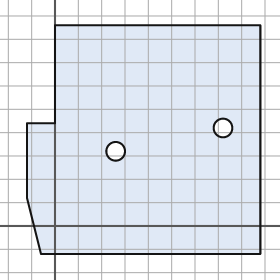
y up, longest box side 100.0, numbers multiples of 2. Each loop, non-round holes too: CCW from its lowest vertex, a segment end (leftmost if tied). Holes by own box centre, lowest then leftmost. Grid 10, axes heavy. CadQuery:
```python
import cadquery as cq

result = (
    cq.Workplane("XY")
    .moveTo(-6.0, -12.0)
    .lineTo(88.0, -12.0)
    .lineTo(88.0, 86.0)
    .lineTo(0.0, 86.0)
    .lineTo(0.0, 44.0)
    .lineTo(-12.0, 44.0)
    .lineTo(-12.0, 12.0)
    .close()
    .moveTo(26.0, 32.0)
    .circle(4.0)
    .moveTo(72.0, 42.0)
    .circle(4.0)
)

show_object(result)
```